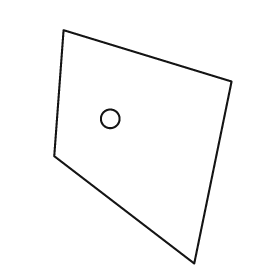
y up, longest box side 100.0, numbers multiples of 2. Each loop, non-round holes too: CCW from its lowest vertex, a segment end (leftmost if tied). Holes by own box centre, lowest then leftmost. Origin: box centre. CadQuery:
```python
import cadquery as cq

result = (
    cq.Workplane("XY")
    .moveTo(22.0, -50.0)
    .lineTo(38.0, 28.0)
    .lineTo(-34.0, 50.0)
    .lineTo(-38.0, -4.0)
    .close()
    .moveTo(-14.0, 12.0)
    .circle(4.0)
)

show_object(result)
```